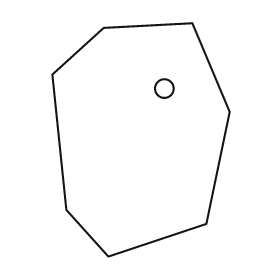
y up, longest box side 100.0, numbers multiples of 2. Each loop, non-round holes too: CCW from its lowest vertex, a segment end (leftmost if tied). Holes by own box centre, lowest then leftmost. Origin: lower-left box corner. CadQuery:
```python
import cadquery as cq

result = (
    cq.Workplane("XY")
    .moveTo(24.0, 0.0)
    .lineTo(66.0, 14.0)
    .lineTo(76.0, 62.0)
    .lineTo(60.0, 100.0)
    .lineTo(22.0, 98.0)
    .lineTo(0.0, 78.0)
    .lineTo(6.0, 20.0)
    .close()
    .moveTo(48.0, 72.0)
    .circle(4.0)
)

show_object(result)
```